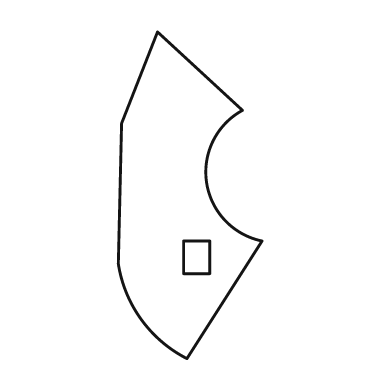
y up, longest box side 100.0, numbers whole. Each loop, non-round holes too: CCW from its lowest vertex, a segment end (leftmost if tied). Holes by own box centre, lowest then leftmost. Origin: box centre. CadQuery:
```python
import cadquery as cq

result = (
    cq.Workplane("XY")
    .moveTo(-1.0, -50.0)
    .lineTo(22.0, -14.0)
    .threePointArc((5.0, 4.0), (16.0, 26.0))
    .lineTo(-10.0, 50.0)
    .lineTo(-21.0, 22.0)
    .lineTo(-22.0, -21.0)
    .threePointArc((-15.0, -38.0), (-1.0, -50.0))
    .close()
    .moveTo(-2.0, -24.0)
    .lineTo(6.0, -24.0)
    .lineTo(6.0, -14.0)
    .lineTo(-2.0, -14.0)
    .close()
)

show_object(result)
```